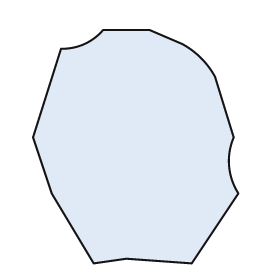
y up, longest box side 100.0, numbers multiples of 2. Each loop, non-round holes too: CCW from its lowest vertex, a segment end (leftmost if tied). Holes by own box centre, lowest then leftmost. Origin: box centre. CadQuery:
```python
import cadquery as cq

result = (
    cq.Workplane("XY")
    .moveTo(-18.0, -50.0)
    .lineTo(-4.0, -48.0)
    .lineTo(24.0, -50.0)
    .lineTo(44.0, -20.0)
    .threePointArc((40.0, -8.0), (42.0, 4.0))
    .lineTo(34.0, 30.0)
    .threePointArc((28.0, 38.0), (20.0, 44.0))
    .lineTo(6.0, 50.0)
    .lineTo(-14.0, 50.0)
    .threePointArc((-22.0, 44.0), (-32.0, 42.0))
    .lineTo(-44.0, 4.0)
    .lineTo(-36.0, -20.0)
    .close()
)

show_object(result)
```